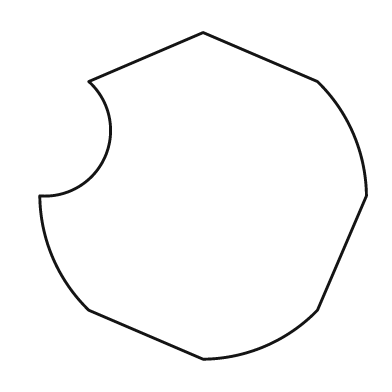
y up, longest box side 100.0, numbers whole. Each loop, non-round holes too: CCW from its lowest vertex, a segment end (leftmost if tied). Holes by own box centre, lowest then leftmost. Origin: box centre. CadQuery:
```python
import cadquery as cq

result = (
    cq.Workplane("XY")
    .moveTo(0.0, -50.0)
    .threePointArc((19.0, -46.0), (35.0, -35.0))
    .lineTo(50.0, 0.0)
    .threePointArc((46.0, 19.0), (35.0, 35.0))
    .lineTo(0.0, 50.0)
    .lineTo(-35.0, 35.0)
    .threePointArc((-30.0, 12.0), (-50.0, 0.0))
    .threePointArc((-46.0, -19.0), (-35.0, -35.0))
    .close()
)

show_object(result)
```